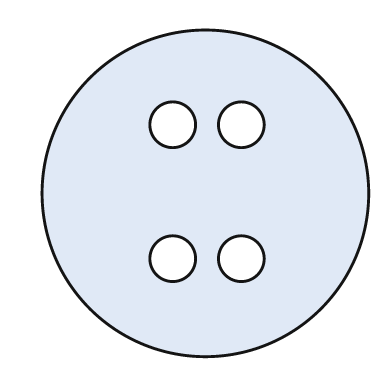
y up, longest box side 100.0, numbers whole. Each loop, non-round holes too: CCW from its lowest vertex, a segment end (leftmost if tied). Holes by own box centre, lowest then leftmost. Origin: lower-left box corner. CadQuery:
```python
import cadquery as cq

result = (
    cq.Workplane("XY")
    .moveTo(50.0, 50.0)
    .circle(50.0)
    .moveTo(40.0, 30.0)
    .circle(7.0)
    .moveTo(61.0, 30.0)
    .circle(7.0)
    .moveTo(40.0, 71.0)
    .circle(7.0)
    .moveTo(61.0, 71.0)
    .circle(7.0)
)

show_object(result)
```